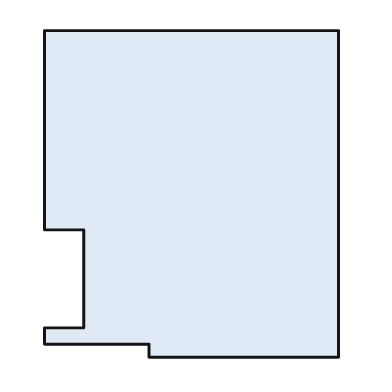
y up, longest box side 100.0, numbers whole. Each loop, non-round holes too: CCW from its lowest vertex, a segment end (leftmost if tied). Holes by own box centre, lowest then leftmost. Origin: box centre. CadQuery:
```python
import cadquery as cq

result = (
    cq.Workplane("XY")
    .moveTo(-13.0, -50.0)
    .lineTo(45.0, -50.0)
    .lineTo(45.0, 50.0)
    .lineTo(-45.0, 50.0)
    .lineTo(-45.0, -11.0)
    .lineTo(-33.0, -11.0)
    .lineTo(-33.0, -41.0)
    .lineTo(-45.0, -41.0)
    .lineTo(-45.0, -46.0)
    .lineTo(-13.0, -46.0)
    .close()
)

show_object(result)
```